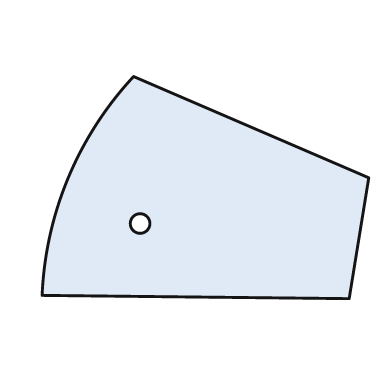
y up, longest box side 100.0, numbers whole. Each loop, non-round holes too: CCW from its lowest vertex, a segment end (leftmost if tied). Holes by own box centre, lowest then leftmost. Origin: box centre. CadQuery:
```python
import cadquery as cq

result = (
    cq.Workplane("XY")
    .moveTo(44.0, -34.0)
    .lineTo(50.0, 3.0)
    .lineTo(-22.0, 34.0)
    .threePointArc((-42.0, 3.0), (-50.0, -33.0))
    .close()
    .moveTo(-20.0, -11.0)
    .circle(3.0)
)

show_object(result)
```